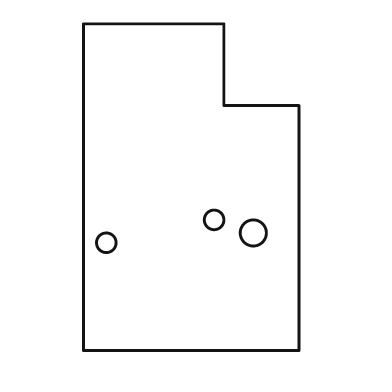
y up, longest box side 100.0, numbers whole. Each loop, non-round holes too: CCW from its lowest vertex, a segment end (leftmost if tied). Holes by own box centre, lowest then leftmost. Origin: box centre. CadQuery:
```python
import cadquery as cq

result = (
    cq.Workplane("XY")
    .moveTo(-33.0, -50.0)
    .lineTo(33.0, -50.0)
    .lineTo(33.0, 25.0)
    .lineTo(10.0, 25.0)
    .lineTo(10.0, 50.0)
    .lineTo(-33.0, 50.0)
    .close()
    .moveTo(-26.0, -17.0)
    .circle(3.0)
    .moveTo(19.0, -14.0)
    .circle(4.0)
    .moveTo(7.0, -10.0)
    .circle(3.0)
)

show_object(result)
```